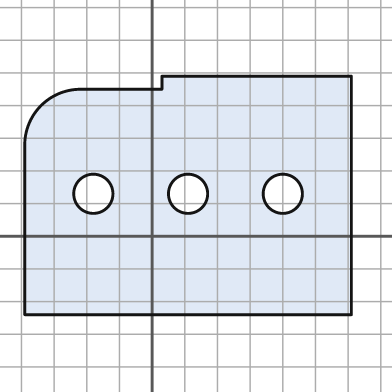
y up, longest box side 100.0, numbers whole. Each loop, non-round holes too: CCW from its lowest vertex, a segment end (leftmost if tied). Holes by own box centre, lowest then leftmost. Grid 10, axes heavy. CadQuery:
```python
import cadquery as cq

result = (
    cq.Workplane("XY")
    .moveTo(-39.0, -24.0)
    .lineTo(61.0, -24.0)
    .lineTo(61.0, 49.0)
    .lineTo(3.0, 49.0)
    .lineTo(3.0, 45.0)
    .lineTo(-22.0, 45.0)
    .threePointArc((-34.0, 40.0), (-39.0, 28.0))
    .close()
    .moveTo(-18.0, 13.0)
    .circle(6.0)
    .moveTo(11.0, 13.0)
    .circle(6.0)
    .moveTo(40.0, 13.0)
    .circle(6.0)
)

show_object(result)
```